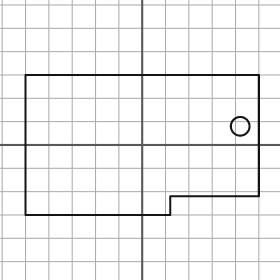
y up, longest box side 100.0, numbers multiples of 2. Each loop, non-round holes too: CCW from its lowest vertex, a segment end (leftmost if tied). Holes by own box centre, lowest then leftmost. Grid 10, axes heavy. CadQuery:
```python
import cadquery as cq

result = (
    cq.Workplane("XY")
    .moveTo(-50.0, -30.0)
    .lineTo(12.0, -30.0)
    .lineTo(12.0, -22.0)
    .lineTo(50.0, -22.0)
    .lineTo(50.0, 30.0)
    .lineTo(-50.0, 30.0)
    .close()
    .moveTo(42.0, 8.0)
    .circle(4.0)
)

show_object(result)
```